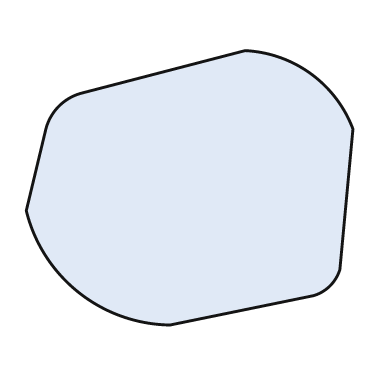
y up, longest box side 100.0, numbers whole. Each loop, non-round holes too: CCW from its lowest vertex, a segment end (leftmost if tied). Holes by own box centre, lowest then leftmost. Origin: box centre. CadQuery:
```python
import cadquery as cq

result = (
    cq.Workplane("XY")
    .moveTo(-6.0, -42.0)
    .lineTo(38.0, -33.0)
    .threePointArc((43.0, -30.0), (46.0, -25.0))
    .lineTo(50.0, 18.0)
    .threePointArc((37.0, 35.0), (17.0, 42.0))
    .lineTo(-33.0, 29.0)
    .threePointArc((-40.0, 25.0), (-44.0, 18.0))
    .lineTo(-50.0, -7.0)
    .threePointArc((-34.0, -32.0), (-6.0, -42.0))
    .close()
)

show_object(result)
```